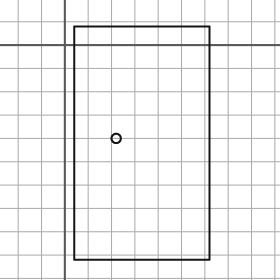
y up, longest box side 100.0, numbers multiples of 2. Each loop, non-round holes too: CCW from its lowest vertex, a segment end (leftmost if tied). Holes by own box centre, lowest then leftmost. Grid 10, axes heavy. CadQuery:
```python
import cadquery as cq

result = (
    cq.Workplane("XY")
    .moveTo(4.0, -92.0)
    .lineTo(62.0, -92.0)
    .lineTo(62.0, 8.0)
    .lineTo(4.0, 8.0)
    .close()
    .moveTo(22.0, -40.0)
    .circle(2.0)
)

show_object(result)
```